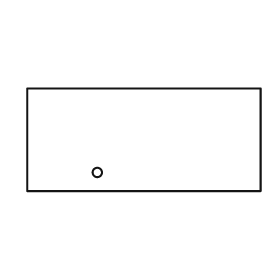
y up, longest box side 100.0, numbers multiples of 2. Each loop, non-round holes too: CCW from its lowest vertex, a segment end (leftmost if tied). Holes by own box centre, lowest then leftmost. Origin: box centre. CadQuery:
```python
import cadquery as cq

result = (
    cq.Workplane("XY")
    .moveTo(-50.0, -22.0)
    .lineTo(50.0, -22.0)
    .lineTo(50.0, 22.0)
    .lineTo(-50.0, 22.0)
    .close()
    .moveTo(-20.0, -14.0)
    .circle(2.0)
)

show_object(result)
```